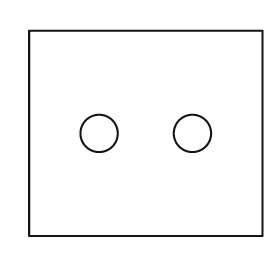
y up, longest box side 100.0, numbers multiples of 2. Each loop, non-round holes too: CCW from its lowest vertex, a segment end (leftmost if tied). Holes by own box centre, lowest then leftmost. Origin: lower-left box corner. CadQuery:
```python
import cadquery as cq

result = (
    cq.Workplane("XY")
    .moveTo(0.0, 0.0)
    .lineTo(100.0, 0.0)
    .lineTo(100.0, 88.0)
    .lineTo(0.0, 88.0)
    .close()
    .moveTo(30.0, 44.0)
    .circle(8.0)
    .moveTo(70.0, 44.0)
    .circle(8.0)
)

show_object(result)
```